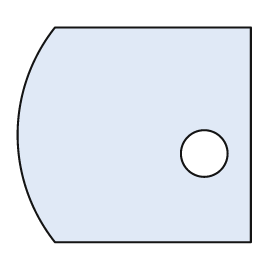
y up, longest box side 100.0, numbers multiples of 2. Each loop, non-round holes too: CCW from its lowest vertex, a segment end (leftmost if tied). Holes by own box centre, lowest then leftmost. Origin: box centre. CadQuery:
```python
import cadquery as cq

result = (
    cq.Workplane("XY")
    .moveTo(-34.0, -46.0)
    .lineTo(50.0, -46.0)
    .lineTo(50.0, 46.0)
    .lineTo(-34.0, 46.0)
    .threePointArc((-50.0, 0.0), (-34.0, -46.0))
    .close()
    .moveTo(30.0, -8.0)
    .circle(10.0)
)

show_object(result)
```